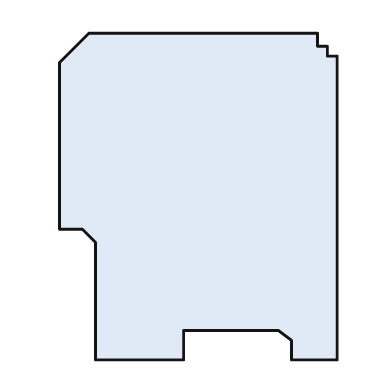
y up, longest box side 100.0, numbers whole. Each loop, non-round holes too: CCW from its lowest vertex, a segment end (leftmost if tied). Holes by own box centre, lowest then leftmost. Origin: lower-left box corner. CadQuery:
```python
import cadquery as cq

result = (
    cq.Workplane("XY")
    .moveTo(11.0, 0.0)
    .lineTo(38.0, 0.0)
    .lineTo(38.0, 9.0)
    .lineTo(67.0, 9.0)
    .lineTo(71.0, 6.0)
    .lineTo(71.0, 0.0)
    .lineTo(85.0, 0.0)
    .lineTo(85.0, 93.0)
    .lineTo(82.0, 93.0)
    .lineTo(82.0, 96.0)
    .lineTo(79.0, 96.0)
    .lineTo(79.0, 100.0)
    .lineTo(9.0, 100.0)
    .lineTo(0.0, 91.0)
    .lineTo(0.0, 40.0)
    .lineTo(7.0, 40.0)
    .lineTo(11.0, 36.0)
    .close()
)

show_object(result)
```